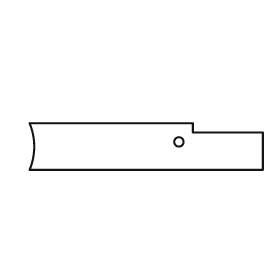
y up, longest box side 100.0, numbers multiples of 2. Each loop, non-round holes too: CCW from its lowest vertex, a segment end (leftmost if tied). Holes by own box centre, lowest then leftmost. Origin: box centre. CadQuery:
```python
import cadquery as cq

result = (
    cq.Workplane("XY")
    .moveTo(-50.0, -10.0)
    .lineTo(50.0, -10.0)
    .lineTo(50.0, 6.0)
    .lineTo(20.0, 6.0)
    .lineTo(20.0, 10.0)
    .lineTo(-50.0, 10.0)
    .threePointArc((-48.0, 0.0), (-50.0, -10.0))
    .close()
    .moveTo(14.0, 2.0)
    .circle(2.0)
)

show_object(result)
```